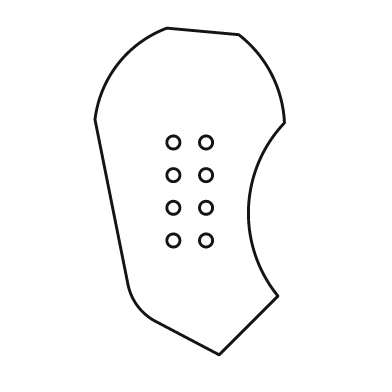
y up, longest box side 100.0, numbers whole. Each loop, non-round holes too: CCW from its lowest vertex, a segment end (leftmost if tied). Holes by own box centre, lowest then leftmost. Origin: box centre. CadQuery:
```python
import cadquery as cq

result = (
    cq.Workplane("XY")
    .moveTo(9.0, -50.0)
    .lineTo(27.0, -32.0)
    .threePointArc((18.0, -5.0), (29.0, 21.0))
    .threePointArc((25.0, 36.0), (15.0, 48.0))
    .lineTo(-7.0, 50.0)
    .threePointArc((-22.0, 39.0), (-29.0, 22.0))
    .lineTo(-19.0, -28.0)
    .threePointArc((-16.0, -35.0), (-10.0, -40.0))
    .close()
    .moveTo(-5.0, -15.0)
    .circle(2.0)
    .moveTo(5.0, -15.0)
    .circle(2.0)
    .moveTo(-5.0, -5.0)
    .circle(2.0)
    .moveTo(5.0, -5.0)
    .circle(2.0)
    .moveTo(-5.0, 5.0)
    .circle(2.0)
    .moveTo(5.0, 5.0)
    .circle(2.0)
    .moveTo(-5.0, 15.0)
    .circle(2.0)
    .moveTo(5.0, 15.0)
    .circle(2.0)
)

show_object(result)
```